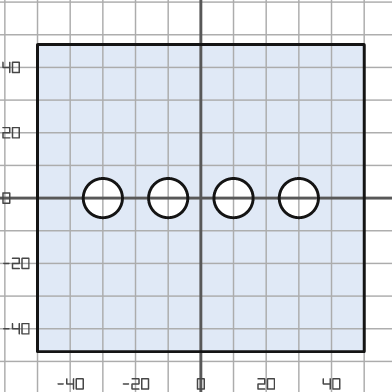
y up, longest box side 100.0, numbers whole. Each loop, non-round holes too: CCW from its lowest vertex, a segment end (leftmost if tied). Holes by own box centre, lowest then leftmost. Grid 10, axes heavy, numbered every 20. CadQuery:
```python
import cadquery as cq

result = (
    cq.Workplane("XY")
    .moveTo(-50.0, -47.0)
    .lineTo(50.0, -47.0)
    .lineTo(50.0, 47.0)
    .lineTo(-50.0, 47.0)
    .close()
    .moveTo(-30.0, 0.0)
    .circle(6.0)
    .moveTo(-10.0, 0.0)
    .circle(6.0)
    .moveTo(10.0, 0.0)
    .circle(6.0)
    .moveTo(30.0, 0.0)
    .circle(6.0)
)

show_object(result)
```